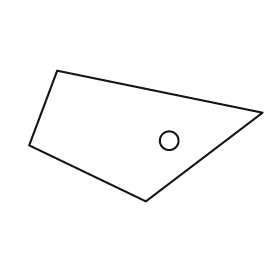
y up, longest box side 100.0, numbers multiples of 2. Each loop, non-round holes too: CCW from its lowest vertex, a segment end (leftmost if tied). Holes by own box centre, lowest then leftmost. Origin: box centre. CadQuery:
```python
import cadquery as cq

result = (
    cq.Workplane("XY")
    .moveTo(0.0, -28.0)
    .lineTo(50.0, 10.0)
    .lineTo(-38.0, 28.0)
    .lineTo(-50.0, -4.0)
    .close()
    .moveTo(10.0, -2.0)
    .circle(4.0)
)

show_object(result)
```